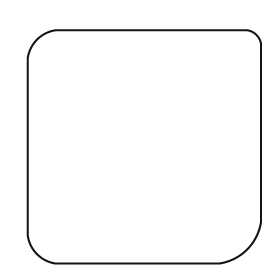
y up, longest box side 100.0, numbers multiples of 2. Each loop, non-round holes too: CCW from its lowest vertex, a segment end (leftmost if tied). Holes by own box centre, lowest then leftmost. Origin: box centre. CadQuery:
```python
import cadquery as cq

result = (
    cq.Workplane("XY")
    .moveTo(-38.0, -50.0)
    .lineTo(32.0, -50.0)
    .threePointArc((44.0, -44.0), (50.0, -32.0))
    .lineTo(50.0, 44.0)
    .threePointArc((48.0, 48.0), (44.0, 50.0))
    .lineTo(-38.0, 50.0)
    .threePointArc((-46.0, 46.0), (-50.0, 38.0))
    .lineTo(-50.0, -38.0)
    .threePointArc((-46.0, -46.0), (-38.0, -50.0))
    .close()
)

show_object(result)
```